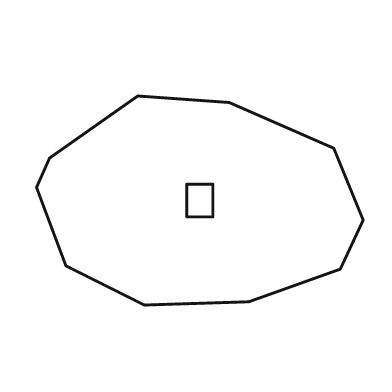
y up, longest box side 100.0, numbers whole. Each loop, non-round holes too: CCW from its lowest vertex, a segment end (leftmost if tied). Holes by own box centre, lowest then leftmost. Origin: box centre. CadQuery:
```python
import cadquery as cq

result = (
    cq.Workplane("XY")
    .moveTo(-17.0, -32.0)
    .lineTo(15.0, -31.0)
    .lineTo(43.0, -21.0)
    .lineTo(50.0, -6.0)
    .lineTo(41.0, 16.0)
    .lineTo(9.0, 30.0)
    .lineTo(-19.0, 32.0)
    .lineTo(-46.0, 13.0)
    .lineTo(-50.0, 4.0)
    .lineTo(-41.0, -20.0)
    .close()
    .moveTo(-4.0, -5.0)
    .lineTo(4.0, -5.0)
    .lineTo(4.0, 5.0)
    .lineTo(-4.0, 5.0)
    .close()
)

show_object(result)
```